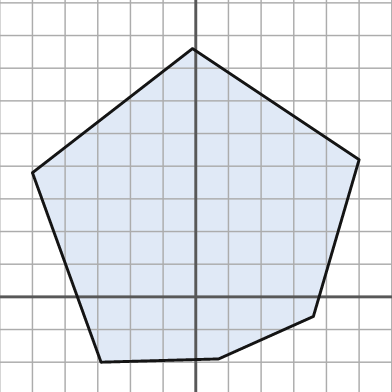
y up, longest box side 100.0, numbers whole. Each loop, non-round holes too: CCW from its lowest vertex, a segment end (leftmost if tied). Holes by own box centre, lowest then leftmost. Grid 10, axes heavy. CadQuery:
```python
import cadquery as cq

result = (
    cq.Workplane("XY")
    .moveTo(-29.0, -20.0)
    .lineTo(7.0, -19.0)
    .lineTo(36.0, -6.0)
    .lineTo(50.0, 42.0)
    .lineTo(-1.0, 76.0)
    .lineTo(-50.0, 38.0)
    .close()
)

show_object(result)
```